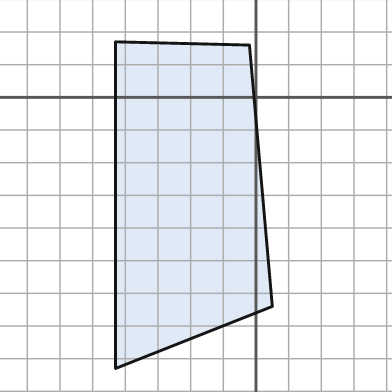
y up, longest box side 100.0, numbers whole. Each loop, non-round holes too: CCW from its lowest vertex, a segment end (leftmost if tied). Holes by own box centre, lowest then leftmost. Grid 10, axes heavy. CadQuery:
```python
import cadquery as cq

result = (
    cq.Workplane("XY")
    .moveTo(-43.0, -83.0)
    .lineTo(5.0, -64.0)
    .lineTo(-2.0, 16.0)
    .lineTo(-43.0, 17.0)
    .close()
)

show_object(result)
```